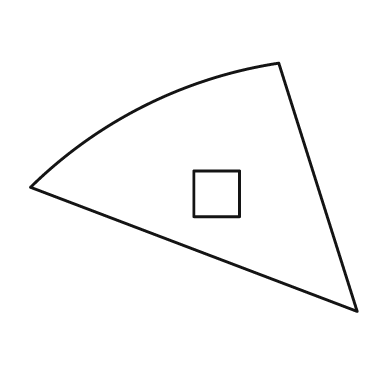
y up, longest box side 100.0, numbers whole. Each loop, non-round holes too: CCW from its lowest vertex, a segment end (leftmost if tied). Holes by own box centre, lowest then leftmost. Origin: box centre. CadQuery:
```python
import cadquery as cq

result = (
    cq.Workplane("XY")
    .moveTo(50.0, -38.0)
    .lineTo(26.0, 38.0)
    .threePointArc((-15.0, 25.0), (-50.0, 0.0))
    .close()
    .moveTo(0.0, -9.0)
    .lineTo(14.0, -9.0)
    .lineTo(14.0, 5.0)
    .lineTo(0.0, 5.0)
    .close()
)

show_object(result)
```